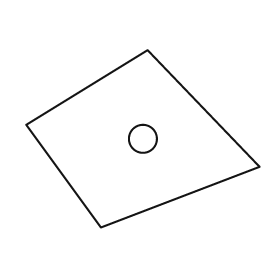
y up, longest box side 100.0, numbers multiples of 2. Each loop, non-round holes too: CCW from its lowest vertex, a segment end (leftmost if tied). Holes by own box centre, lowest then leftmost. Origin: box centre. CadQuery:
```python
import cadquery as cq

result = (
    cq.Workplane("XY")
    .moveTo(-18.0, -38.0)
    .lineTo(50.0, -12.0)
    .lineTo(2.0, 38.0)
    .lineTo(-50.0, 6.0)
    .close()
    .moveTo(0.0, 0.0)
    .circle(6.0)
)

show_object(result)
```